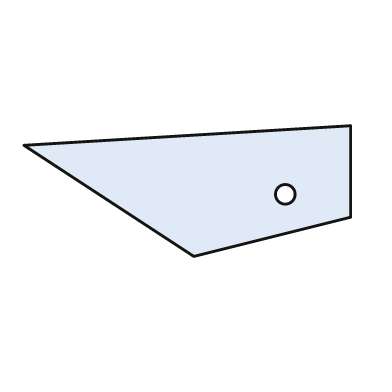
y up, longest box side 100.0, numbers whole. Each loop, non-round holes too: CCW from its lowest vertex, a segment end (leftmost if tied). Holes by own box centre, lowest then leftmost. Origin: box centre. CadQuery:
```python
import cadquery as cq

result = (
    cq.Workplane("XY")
    .moveTo(2.0, -20.0)
    .lineTo(50.0, -8.0)
    .lineTo(50.0, 20.0)
    .lineTo(-50.0, 14.0)
    .close()
    .moveTo(30.0, -1.0)
    .circle(3.0)
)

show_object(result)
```